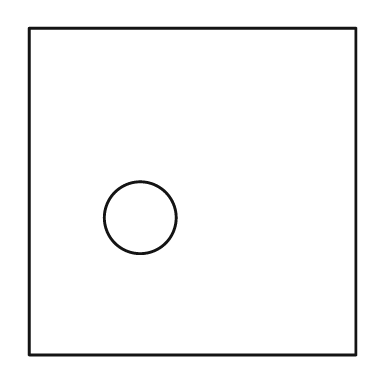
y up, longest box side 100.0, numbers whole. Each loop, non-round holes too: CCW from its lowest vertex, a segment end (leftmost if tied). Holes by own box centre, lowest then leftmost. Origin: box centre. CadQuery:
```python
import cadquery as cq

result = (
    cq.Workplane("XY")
    .moveTo(-50.0, -50.0)
    .lineTo(50.0, -50.0)
    .lineTo(50.0, 50.0)
    .lineTo(-50.0, 50.0)
    .close()
    .moveTo(-16.0, -8.0)
    .circle(11.0)
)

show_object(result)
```